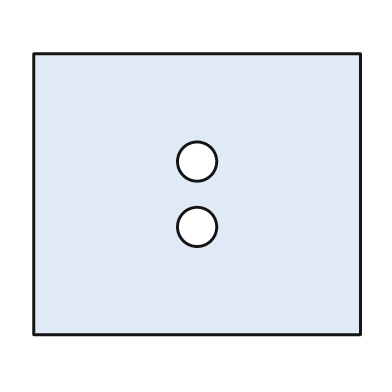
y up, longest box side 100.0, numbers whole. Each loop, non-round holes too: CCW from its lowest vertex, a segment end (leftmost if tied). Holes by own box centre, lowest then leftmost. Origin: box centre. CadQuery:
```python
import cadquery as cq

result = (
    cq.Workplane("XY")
    .moveTo(-50.0, -43.0)
    .lineTo(50.0, -43.0)
    .lineTo(50.0, 43.0)
    .lineTo(-50.0, 43.0)
    .close()
    .moveTo(0.0, -10.0)
    .circle(6.0)
    .moveTo(0.0, 10.0)
    .circle(6.0)
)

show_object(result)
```